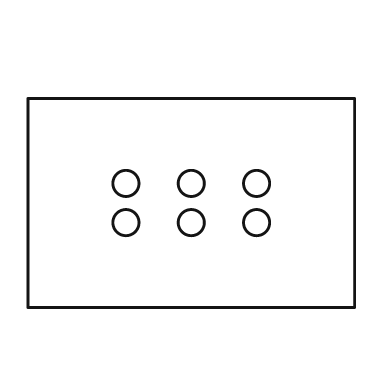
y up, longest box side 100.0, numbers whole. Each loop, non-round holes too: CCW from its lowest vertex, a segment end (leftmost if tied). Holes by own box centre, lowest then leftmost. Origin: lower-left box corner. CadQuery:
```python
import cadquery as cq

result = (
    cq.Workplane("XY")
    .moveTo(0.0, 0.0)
    .lineTo(100.0, 0.0)
    .lineTo(100.0, 64.0)
    .lineTo(0.0, 64.0)
    .close()
    .moveTo(30.0, 26.0)
    .circle(4.0)
    .moveTo(50.0, 26.0)
    .circle(4.0)
    .moveTo(70.0, 26.0)
    .circle(4.0)
    .moveTo(30.0, 38.0)
    .circle(4.0)
    .moveTo(50.0, 38.0)
    .circle(4.0)
    .moveTo(70.0, 38.0)
    .circle(4.0)
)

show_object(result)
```